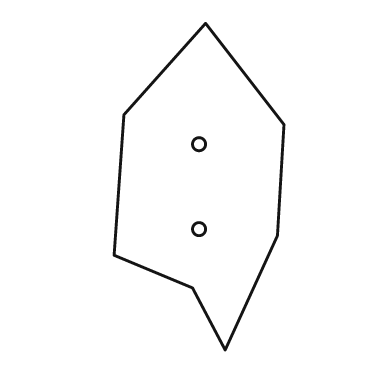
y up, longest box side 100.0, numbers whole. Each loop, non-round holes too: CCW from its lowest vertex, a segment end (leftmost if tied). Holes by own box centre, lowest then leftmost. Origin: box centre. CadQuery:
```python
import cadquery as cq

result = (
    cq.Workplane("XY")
    .moveTo(8.0, -50.0)
    .lineTo(24.0, -15.0)
    .lineTo(26.0, 19.0)
    .lineTo(2.0, 50.0)
    .lineTo(-23.0, 22.0)
    .lineTo(-26.0, -21.0)
    .lineTo(-2.0, -31.0)
    .close()
    .moveTo(0.0, -13.0)
    .circle(2.0)
    .moveTo(0.0, 13.0)
    .circle(2.0)
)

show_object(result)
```